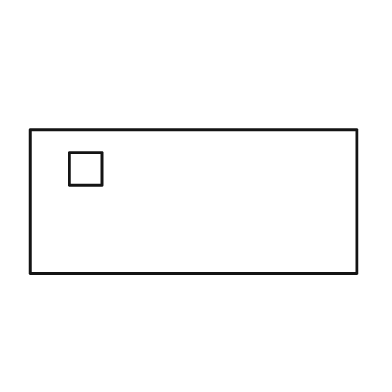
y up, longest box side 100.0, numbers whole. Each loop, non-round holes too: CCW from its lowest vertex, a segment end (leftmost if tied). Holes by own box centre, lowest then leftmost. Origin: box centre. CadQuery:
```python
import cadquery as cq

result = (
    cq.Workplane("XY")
    .moveTo(-50.0, -22.0)
    .lineTo(50.0, -22.0)
    .lineTo(50.0, 22.0)
    .lineTo(-50.0, 22.0)
    .close()
    .moveTo(-38.0, 5.0)
    .lineTo(-28.0, 5.0)
    .lineTo(-28.0, 15.0)
    .lineTo(-38.0, 15.0)
    .close()
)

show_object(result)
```